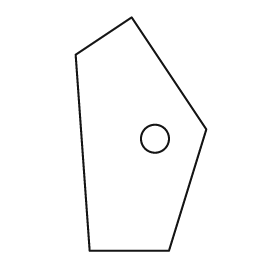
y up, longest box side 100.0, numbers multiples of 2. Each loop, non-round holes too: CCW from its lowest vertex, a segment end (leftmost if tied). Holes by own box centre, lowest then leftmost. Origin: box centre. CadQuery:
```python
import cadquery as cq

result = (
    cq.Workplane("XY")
    .moveTo(-22.0, -50.0)
    .lineTo(12.0, -50.0)
    .lineTo(28.0, 2.0)
    .lineTo(-4.0, 50.0)
    .lineTo(-28.0, 34.0)
    .close()
    .moveTo(6.0, -2.0)
    .circle(6.0)
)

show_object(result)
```